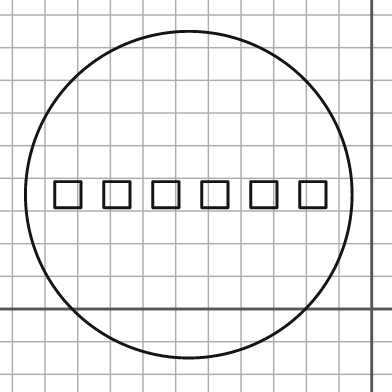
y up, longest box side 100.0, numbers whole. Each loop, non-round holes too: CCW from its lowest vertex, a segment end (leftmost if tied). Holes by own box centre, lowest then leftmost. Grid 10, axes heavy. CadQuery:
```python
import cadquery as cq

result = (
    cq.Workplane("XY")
    .moveTo(-56.0, 35.0)
    .circle(50.0)
    .moveTo(-97.0, 31.0)
    .lineTo(-89.0, 31.0)
    .lineTo(-89.0, 39.0)
    .lineTo(-97.0, 39.0)
    .close()
    .moveTo(-82.0, 31.0)
    .lineTo(-74.0, 31.0)
    .lineTo(-74.0, 39.0)
    .lineTo(-82.0, 39.0)
    .close()
    .moveTo(-67.0, 31.0)
    .lineTo(-59.0, 31.0)
    .lineTo(-59.0, 39.0)
    .lineTo(-67.0, 39.0)
    .close()
    .moveTo(-52.0, 31.0)
    .lineTo(-44.0, 31.0)
    .lineTo(-44.0, 39.0)
    .lineTo(-52.0, 39.0)
    .close()
    .moveTo(-37.0, 31.0)
    .lineTo(-29.0, 31.0)
    .lineTo(-29.0, 39.0)
    .lineTo(-37.0, 39.0)
    .close()
    .moveTo(-22.0, 31.0)
    .lineTo(-14.0, 31.0)
    .lineTo(-14.0, 39.0)
    .lineTo(-22.0, 39.0)
    .close()
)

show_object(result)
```